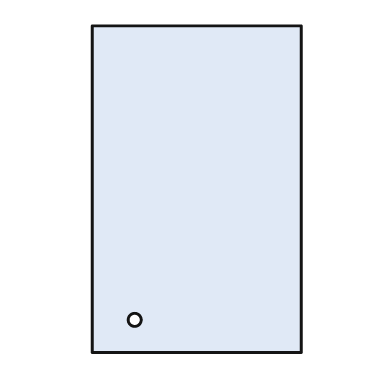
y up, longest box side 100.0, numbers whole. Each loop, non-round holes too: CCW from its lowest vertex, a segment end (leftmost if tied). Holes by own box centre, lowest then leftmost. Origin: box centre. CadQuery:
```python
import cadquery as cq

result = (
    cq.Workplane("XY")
    .moveTo(-32.0, -50.0)
    .lineTo(32.0, -50.0)
    .lineTo(32.0, 50.0)
    .lineTo(-32.0, 50.0)
    .close()
    .moveTo(-19.0, -40.0)
    .circle(2.0)
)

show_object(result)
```